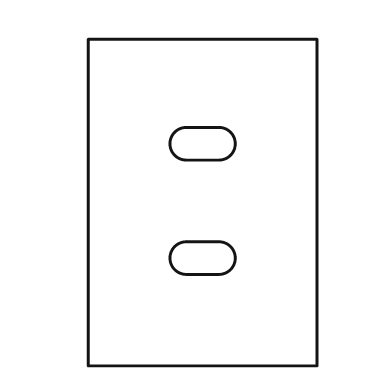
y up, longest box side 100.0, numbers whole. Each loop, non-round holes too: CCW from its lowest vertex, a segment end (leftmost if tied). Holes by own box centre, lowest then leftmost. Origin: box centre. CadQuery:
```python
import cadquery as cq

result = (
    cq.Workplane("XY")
    .moveTo(-35.0, -50.0)
    .lineTo(35.0, -50.0)
    .lineTo(35.0, 50.0)
    .lineTo(-35.0, 50.0)
    .close()
    .moveTo(-5.0, -22.0)
    .lineTo(5.0, -22.0)
    .threePointArc((10.0, -17.0), (5.0, -12.0))
    .lineTo(-5.0, -12.0)
    .threePointArc((-10.0, -17.0), (-5.0, -22.0))
    .close()
    .moveTo(-5.0, 13.0)
    .lineTo(5.0, 13.0)
    .threePointArc((10.0, 18.0), (5.0, 23.0))
    .lineTo(-5.0, 23.0)
    .threePointArc((-10.0, 18.0), (-5.0, 13.0))
    .close()
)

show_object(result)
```